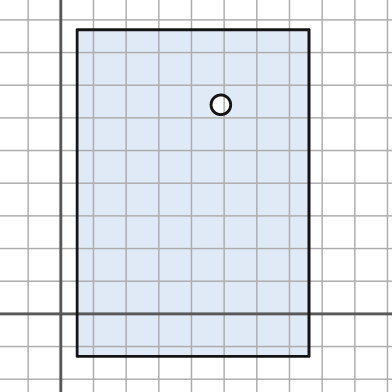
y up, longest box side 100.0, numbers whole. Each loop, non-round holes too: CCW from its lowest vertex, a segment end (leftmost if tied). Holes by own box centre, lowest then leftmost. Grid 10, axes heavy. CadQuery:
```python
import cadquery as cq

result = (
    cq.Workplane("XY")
    .moveTo(5.0, -13.0)
    .lineTo(76.0, -13.0)
    .lineTo(76.0, 87.0)
    .lineTo(5.0, 87.0)
    .close()
    .moveTo(49.0, 64.0)
    .circle(3.0)
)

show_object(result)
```